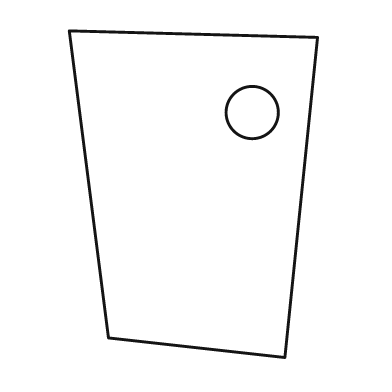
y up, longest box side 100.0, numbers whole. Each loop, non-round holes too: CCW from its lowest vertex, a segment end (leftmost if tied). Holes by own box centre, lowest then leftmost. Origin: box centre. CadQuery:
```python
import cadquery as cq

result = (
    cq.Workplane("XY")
    .moveTo(28.0, -50.0)
    .lineTo(38.0, 48.0)
    .lineTo(-38.0, 50.0)
    .lineTo(-26.0, -44.0)
    .close()
    .moveTo(18.0, 25.0)
    .circle(8.0)
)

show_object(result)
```